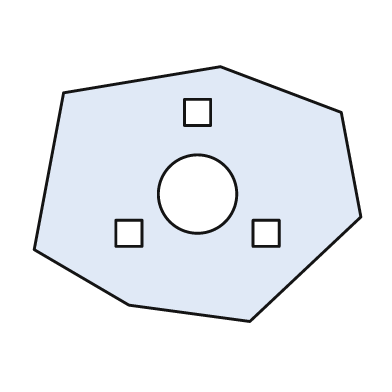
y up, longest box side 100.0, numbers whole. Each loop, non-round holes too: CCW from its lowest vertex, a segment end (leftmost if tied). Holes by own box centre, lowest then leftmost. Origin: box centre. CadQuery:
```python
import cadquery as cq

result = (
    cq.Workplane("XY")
    .moveTo(16.0, -39.0)
    .lineTo(50.0, -7.0)
    .lineTo(44.0, 25.0)
    .lineTo(7.0, 39.0)
    .lineTo(-41.0, 31.0)
    .lineTo(-50.0, -17.0)
    .lineTo(-21.0, -34.0)
    .close()
    .moveTo(-25.0, -16.0)
    .lineTo(-17.0, -16.0)
    .lineTo(-17.0, -8.0)
    .lineTo(-25.0, -8.0)
    .close()
    .moveTo(17.0, -16.0)
    .lineTo(25.0, -16.0)
    .lineTo(25.0, -8.0)
    .lineTo(17.0, -8.0)
    .close()
    .moveTo(0.0, 0.0)
    .circle(12.0)
    .moveTo(-4.0, 21.0)
    .lineTo(4.0, 21.0)
    .lineTo(4.0, 29.0)
    .lineTo(-4.0, 29.0)
    .close()
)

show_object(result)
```